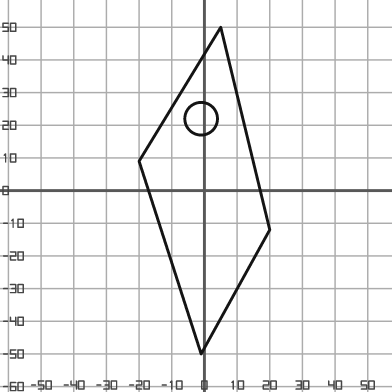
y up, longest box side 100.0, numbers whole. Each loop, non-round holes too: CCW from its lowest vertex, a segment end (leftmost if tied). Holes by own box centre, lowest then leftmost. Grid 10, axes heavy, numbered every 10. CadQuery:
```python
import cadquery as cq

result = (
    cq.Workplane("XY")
    .moveTo(-1.0, -50.0)
    .lineTo(20.0, -12.0)
    .lineTo(5.0, 50.0)
    .lineTo(-20.0, 9.0)
    .close()
    .moveTo(-1.0, 22.0)
    .circle(5.0)
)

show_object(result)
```